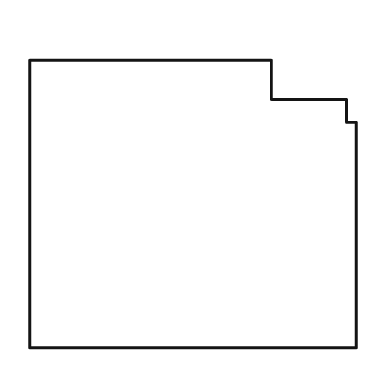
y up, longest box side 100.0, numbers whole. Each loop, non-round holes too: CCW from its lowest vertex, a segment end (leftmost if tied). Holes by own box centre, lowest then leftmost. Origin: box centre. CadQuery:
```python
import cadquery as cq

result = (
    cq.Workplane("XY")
    .moveTo(-50.0, -44.0)
    .lineTo(50.0, -44.0)
    .lineTo(50.0, 25.0)
    .lineTo(47.0, 25.0)
    .lineTo(47.0, 32.0)
    .lineTo(24.0, 32.0)
    .lineTo(24.0, 44.0)
    .lineTo(-50.0, 44.0)
    .close()
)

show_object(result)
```